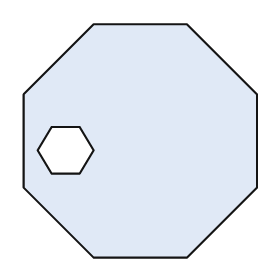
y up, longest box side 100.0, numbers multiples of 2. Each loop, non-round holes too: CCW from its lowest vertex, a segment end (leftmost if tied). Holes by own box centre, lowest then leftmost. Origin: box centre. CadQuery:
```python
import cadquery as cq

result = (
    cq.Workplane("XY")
    .moveTo(-20.0, -50.0)
    .lineTo(20.0, -50.0)
    .lineTo(50.0, -20.0)
    .lineTo(50.0, 20.0)
    .lineTo(20.0, 50.0)
    .lineTo(-20.0, 50.0)
    .lineTo(-50.0, 20.0)
    .lineTo(-50.0, -20.0)
    .close()
    .moveTo(-38.0, -14.0)
    .lineTo(-26.0, -14.0)
    .lineTo(-20.0, -4.0)
    .lineTo(-26.0, 6.0)
    .lineTo(-38.0, 6.0)
    .lineTo(-44.0, -4.0)
    .close()
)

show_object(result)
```